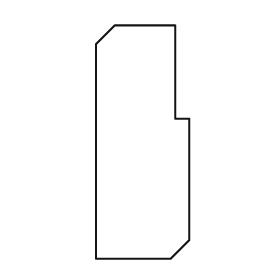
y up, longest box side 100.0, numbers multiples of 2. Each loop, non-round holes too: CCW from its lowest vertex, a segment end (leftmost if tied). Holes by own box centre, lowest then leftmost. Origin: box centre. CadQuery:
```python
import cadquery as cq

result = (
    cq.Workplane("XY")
    .moveTo(-20.0, -50.0)
    .lineTo(12.0, -50.0)
    .lineTo(20.0, -42.0)
    .lineTo(20.0, 10.0)
    .lineTo(14.0, 10.0)
    .lineTo(14.0, 50.0)
    .lineTo(-12.0, 50.0)
    .lineTo(-20.0, 42.0)
    .close()
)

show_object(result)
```